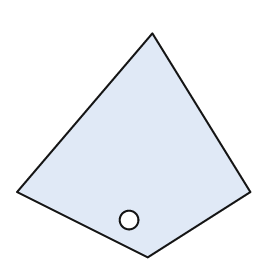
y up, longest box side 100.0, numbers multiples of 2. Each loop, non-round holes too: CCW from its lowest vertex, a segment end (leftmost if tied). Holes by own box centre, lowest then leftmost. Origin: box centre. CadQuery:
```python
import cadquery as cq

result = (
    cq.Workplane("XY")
    .moveTo(6.0, -48.0)
    .lineTo(50.0, -20.0)
    .lineTo(8.0, 48.0)
    .lineTo(-50.0, -20.0)
    .close()
    .moveTo(-2.0, -32.0)
    .circle(4.0)
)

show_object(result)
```